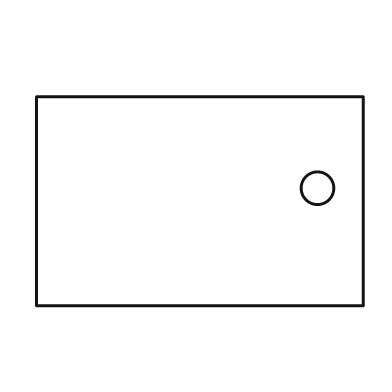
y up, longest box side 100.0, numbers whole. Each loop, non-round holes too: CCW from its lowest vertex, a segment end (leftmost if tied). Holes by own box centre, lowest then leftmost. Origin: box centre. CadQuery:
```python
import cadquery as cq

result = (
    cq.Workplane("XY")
    .moveTo(-50.0, -32.0)
    .lineTo(50.0, -32.0)
    .lineTo(50.0, 32.0)
    .lineTo(-50.0, 32.0)
    .close()
    .moveTo(36.0, 4.0)
    .circle(5.0)
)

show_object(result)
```